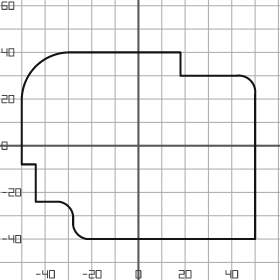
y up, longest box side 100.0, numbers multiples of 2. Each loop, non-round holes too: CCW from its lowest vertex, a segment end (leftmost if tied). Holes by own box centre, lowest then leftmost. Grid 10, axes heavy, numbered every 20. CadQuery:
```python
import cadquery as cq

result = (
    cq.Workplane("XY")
    .moveTo(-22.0, -40.0)
    .lineTo(50.0, -40.0)
    .lineTo(50.0, 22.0)
    .threePointArc((48.0, 28.0), (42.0, 30.0))
    .lineTo(18.0, 30.0)
    .lineTo(18.0, 40.0)
    .lineTo(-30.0, 40.0)
    .threePointArc((-44.0, 34.0), (-50.0, 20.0))
    .lineTo(-50.0, -8.0)
    .lineTo(-44.0, -8.0)
    .lineTo(-44.0, -24.0)
    .lineTo(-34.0, -24.0)
    .threePointArc((-30.0, -26.0), (-28.0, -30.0))
    .lineTo(-28.0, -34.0)
    .threePointArc((-26.0, -38.0), (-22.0, -40.0))
    .close()
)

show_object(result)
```